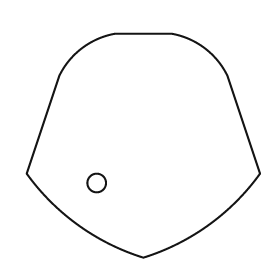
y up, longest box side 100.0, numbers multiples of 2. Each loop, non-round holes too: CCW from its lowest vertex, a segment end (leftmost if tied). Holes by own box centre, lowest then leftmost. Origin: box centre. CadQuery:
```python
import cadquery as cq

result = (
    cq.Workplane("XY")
    .moveTo(0.0, -48.0)
    .threePointArc((28.0, -34.0), (50.0, -12.0))
    .lineTo(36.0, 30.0)
    .threePointArc((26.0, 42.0), (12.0, 48.0))
    .lineTo(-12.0, 48.0)
    .threePointArc((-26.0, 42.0), (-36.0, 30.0))
    .lineTo(-50.0, -12.0)
    .threePointArc((-28.0, -34.0), (0.0, -48.0))
    .close()
    .moveTo(-20.0, -16.0)
    .circle(4.0)
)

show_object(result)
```